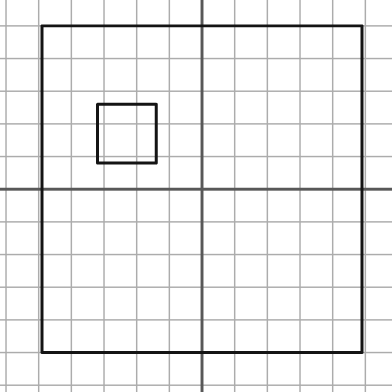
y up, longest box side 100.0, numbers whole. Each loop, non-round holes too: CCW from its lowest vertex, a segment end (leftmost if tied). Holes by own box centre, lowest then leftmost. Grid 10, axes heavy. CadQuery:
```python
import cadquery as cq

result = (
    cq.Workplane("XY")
    .moveTo(-49.0, -50.0)
    .lineTo(49.0, -50.0)
    .lineTo(49.0, 50.0)
    .lineTo(-49.0, 50.0)
    .close()
    .moveTo(-32.0, 8.0)
    .lineTo(-14.0, 8.0)
    .lineTo(-14.0, 26.0)
    .lineTo(-32.0, 26.0)
    .close()
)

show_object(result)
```